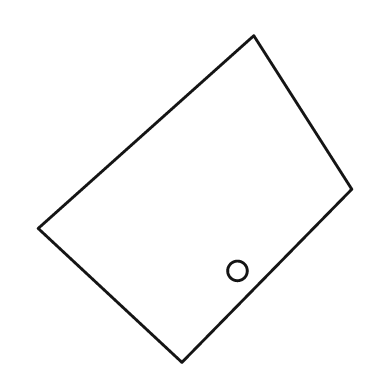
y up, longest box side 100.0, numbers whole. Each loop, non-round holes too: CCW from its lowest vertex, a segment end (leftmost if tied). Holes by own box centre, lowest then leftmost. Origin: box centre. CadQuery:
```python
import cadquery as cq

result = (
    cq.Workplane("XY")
    .moveTo(-4.0, -50.0)
    .lineTo(48.0, 3.0)
    .lineTo(18.0, 50.0)
    .lineTo(-48.0, -9.0)
    .close()
    .moveTo(13.0, -22.0)
    .circle(3.0)
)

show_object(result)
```